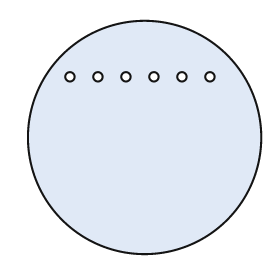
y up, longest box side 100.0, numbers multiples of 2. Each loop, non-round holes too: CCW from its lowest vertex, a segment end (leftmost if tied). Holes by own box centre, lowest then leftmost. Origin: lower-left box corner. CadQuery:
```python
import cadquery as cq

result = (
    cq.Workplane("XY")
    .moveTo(50.0, 50.0)
    .circle(50.0)
    .moveTo(18.0, 76.0)
    .circle(2.0)
    .moveTo(30.0, 76.0)
    .circle(2.0)
    .moveTo(42.0, 76.0)
    .circle(2.0)
    .moveTo(54.0, 76.0)
    .circle(2.0)
    .moveTo(66.0, 76.0)
    .circle(2.0)
    .moveTo(78.0, 76.0)
    .circle(2.0)
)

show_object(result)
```